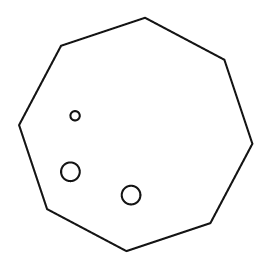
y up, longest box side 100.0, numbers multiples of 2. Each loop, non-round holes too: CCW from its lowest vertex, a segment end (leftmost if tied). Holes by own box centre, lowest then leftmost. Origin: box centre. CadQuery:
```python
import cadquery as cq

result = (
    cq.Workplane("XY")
    .moveTo(-4.0, -50.0)
    .lineTo(32.0, -38.0)
    .lineTo(50.0, -4.0)
    .lineTo(38.0, 32.0)
    .lineTo(4.0, 50.0)
    .lineTo(-32.0, 38.0)
    .lineTo(-50.0, 4.0)
    .lineTo(-38.0, -32.0)
    .close()
    .moveTo(-2.0, -26.0)
    .circle(4.0)
    .moveTo(-28.0, -16.0)
    .circle(4.0)
    .moveTo(-26.0, 8.0)
    .circle(2.0)
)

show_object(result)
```